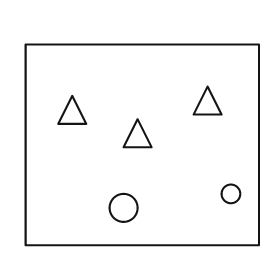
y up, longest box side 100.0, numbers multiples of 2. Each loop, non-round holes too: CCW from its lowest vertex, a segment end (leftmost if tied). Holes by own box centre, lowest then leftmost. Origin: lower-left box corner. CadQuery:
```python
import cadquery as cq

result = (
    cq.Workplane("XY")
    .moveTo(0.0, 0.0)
    .lineTo(100.0, 0.0)
    .lineTo(100.0, 86.0)
    .lineTo(0.0, 86.0)
    .close()
    .moveTo(42.0, 16.0)
    .circle(6.0)
    .moveTo(88.0, 22.0)
    .circle(4.0)
    .moveTo(42.0, 42.0)
    .lineTo(54.0, 42.0)
    .lineTo(48.0, 54.0)
    .close()
    .moveTo(14.0, 52.0)
    .lineTo(26.0, 52.0)
    .lineTo(20.0, 64.0)
    .close()
    .moveTo(72.0, 56.0)
    .lineTo(84.0, 56.0)
    .lineTo(78.0, 68.0)
    .close()
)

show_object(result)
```